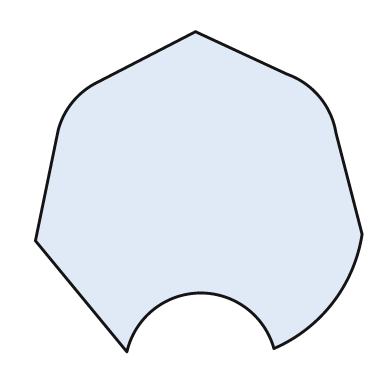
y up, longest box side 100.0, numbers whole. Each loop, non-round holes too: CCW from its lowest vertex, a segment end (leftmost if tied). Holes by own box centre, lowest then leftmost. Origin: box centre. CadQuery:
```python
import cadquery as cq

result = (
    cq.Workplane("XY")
    .moveTo(-22.0, -49.0)
    .threePointArc((0.0, -31.0), (23.0, -48.0))
    .threePointArc((41.0, -34.0), (50.0, -13.0))
    .lineTo(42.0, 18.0)
    .threePointArc((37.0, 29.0), (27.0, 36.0))
    .lineTo(-1.0, 49.0)
    .lineTo(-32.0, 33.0)
    .threePointArc((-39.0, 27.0), (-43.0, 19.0))
    .lineTo(-50.0, -15.0)
    .close()
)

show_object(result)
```